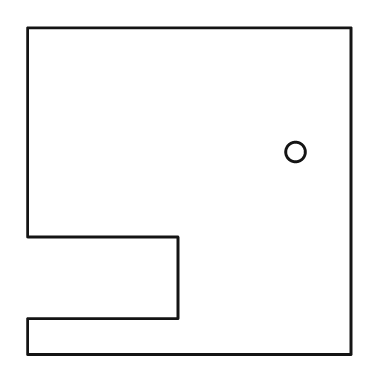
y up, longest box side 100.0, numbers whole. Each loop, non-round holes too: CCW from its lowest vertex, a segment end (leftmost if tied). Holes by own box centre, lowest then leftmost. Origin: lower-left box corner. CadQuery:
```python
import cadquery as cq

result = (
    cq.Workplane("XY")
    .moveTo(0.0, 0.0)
    .lineTo(99.0, 0.0)
    .lineTo(99.0, 100.0)
    .lineTo(0.0, 100.0)
    .lineTo(0.0, 36.0)
    .lineTo(46.0, 36.0)
    .lineTo(46.0, 11.0)
    .lineTo(0.0, 11.0)
    .close()
    .moveTo(82.0, 62.0)
    .circle(3.0)
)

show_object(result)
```